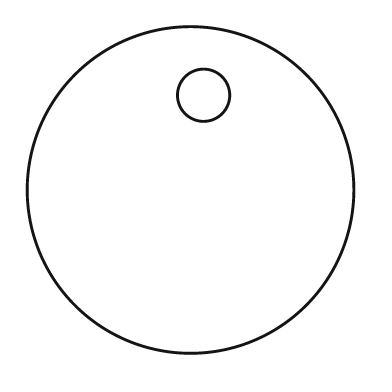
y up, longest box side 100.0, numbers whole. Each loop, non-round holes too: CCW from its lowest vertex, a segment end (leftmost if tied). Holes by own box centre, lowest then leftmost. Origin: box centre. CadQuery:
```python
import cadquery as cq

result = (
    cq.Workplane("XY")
    .moveTo(0.0, 0.0)
    .circle(50.0)
    .moveTo(4.0, 29.0)
    .circle(8.0)
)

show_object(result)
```